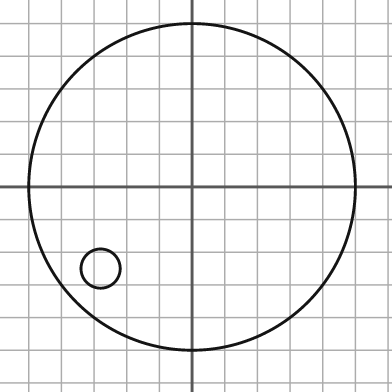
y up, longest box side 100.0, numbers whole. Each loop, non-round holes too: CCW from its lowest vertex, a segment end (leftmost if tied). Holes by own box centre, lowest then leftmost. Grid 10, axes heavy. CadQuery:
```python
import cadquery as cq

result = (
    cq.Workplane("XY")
    .moveTo(0.0, 0.0)
    .circle(50.0)
    .moveTo(-28.0, -25.0)
    .circle(6.0)
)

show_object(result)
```